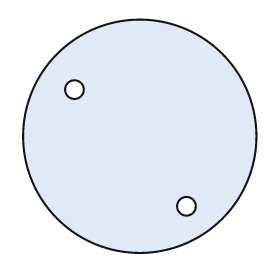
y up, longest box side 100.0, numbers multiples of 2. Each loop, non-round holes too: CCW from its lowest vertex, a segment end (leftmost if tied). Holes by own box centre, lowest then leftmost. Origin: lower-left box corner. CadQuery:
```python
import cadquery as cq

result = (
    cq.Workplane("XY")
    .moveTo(50.0, 50.0)
    .circle(50.0)
    .moveTo(70.0, 20.0)
    .circle(4.0)
    .moveTo(22.0, 70.0)
    .circle(4.0)
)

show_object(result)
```